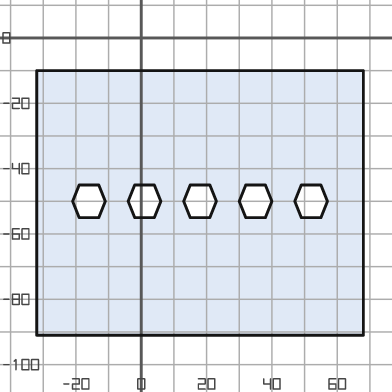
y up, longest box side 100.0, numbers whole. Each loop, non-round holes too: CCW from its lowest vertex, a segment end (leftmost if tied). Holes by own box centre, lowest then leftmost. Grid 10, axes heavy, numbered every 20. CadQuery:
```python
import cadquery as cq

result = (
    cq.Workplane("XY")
    .moveTo(-32.0, -91.0)
    .lineTo(68.0, -91.0)
    .lineTo(68.0, -10.0)
    .lineTo(-32.0, -10.0)
    .close()
    .moveTo(-19.0, -55.0)
    .lineTo(-13.0, -55.0)
    .lineTo(-11.0, -50.0)
    .lineTo(-13.0, -45.0)
    .lineTo(-19.0, -45.0)
    .lineTo(-21.0, -50.0)
    .close()
    .moveTo(-2.0, -55.0)
    .lineTo(4.0, -55.0)
    .lineTo(6.0, -50.0)
    .lineTo(4.0, -45.0)
    .lineTo(-2.0, -45.0)
    .lineTo(-4.0, -50.0)
    .close()
    .moveTo(15.0, -55.0)
    .lineTo(21.0, -55.0)
    .lineTo(23.0, -50.0)
    .lineTo(21.0, -45.0)
    .lineTo(15.0, -45.0)
    .lineTo(13.0, -50.0)
    .close()
    .moveTo(32.0, -55.0)
    .lineTo(38.0, -55.0)
    .lineTo(40.0, -50.0)
    .lineTo(38.0, -45.0)
    .lineTo(32.0, -45.0)
    .lineTo(30.0, -50.0)
    .close()
    .moveTo(49.0, -55.0)
    .lineTo(55.0, -55.0)
    .lineTo(57.0, -50.0)
    .lineTo(55.0, -45.0)
    .lineTo(49.0, -45.0)
    .lineTo(47.0, -50.0)
    .close()
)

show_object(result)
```